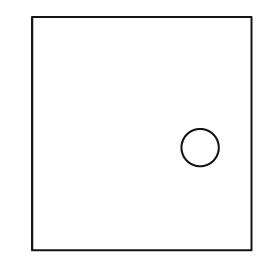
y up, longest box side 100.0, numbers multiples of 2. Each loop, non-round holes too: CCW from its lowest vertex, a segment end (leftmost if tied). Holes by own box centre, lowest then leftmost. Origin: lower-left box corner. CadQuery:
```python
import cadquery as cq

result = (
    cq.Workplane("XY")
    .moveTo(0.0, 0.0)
    .lineTo(94.0, 0.0)
    .lineTo(94.0, 100.0)
    .lineTo(0.0, 100.0)
    .close()
    .moveTo(72.0, 44.0)
    .circle(8.0)
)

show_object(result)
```